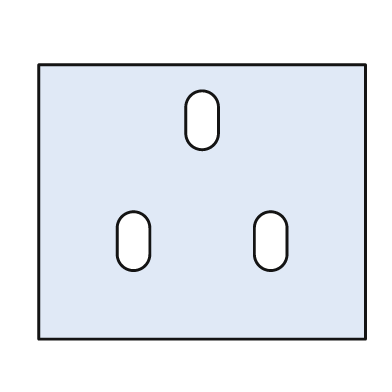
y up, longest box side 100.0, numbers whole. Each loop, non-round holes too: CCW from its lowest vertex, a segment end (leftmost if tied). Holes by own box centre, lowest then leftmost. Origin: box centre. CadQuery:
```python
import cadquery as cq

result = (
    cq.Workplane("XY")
    .moveTo(-50.0, -42.0)
    .lineTo(50.0, -42.0)
    .lineTo(50.0, 42.0)
    .lineTo(-50.0, 42.0)
    .close()
    .moveTo(-26.0, -16.0)
    .threePointArc((-21.0, -21.0), (-16.0, -16.0))
    .lineTo(-16.0, -8.0)
    .threePointArc((-21.0, -3.0), (-26.0, -8.0))
    .close()
    .moveTo(16.0, -16.0)
    .threePointArc((21.0, -21.0), (26.0, -16.0))
    .lineTo(26.0, -8.0)
    .threePointArc((21.0, -3.0), (16.0, -8.0))
    .close()
    .moveTo(-5.0, 21.0)
    .threePointArc((0.0, 16.0), (5.0, 21.0))
    .lineTo(5.0, 29.0)
    .threePointArc((0.0, 34.0), (-5.0, 29.0))
    .close()
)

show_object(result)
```